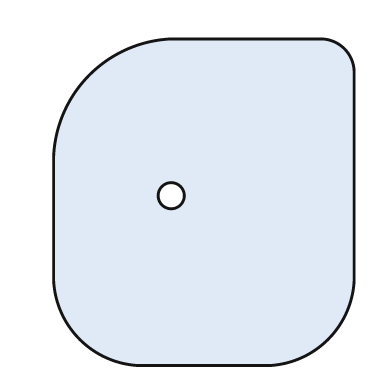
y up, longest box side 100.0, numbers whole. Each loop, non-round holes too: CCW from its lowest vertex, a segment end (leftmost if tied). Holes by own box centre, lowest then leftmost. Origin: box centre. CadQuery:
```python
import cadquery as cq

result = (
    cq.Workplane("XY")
    .moveTo(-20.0, -50.0)
    .lineTo(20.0, -50.0)
    .threePointArc((38.0, -42.0), (46.0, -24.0))
    .lineTo(46.0, 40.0)
    .threePointArc((43.0, 47.0), (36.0, 50.0))
    .lineTo(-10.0, 50.0)
    .threePointArc((-35.0, 39.0), (-46.0, 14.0))
    .lineTo(-46.0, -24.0)
    .threePointArc((-38.0, -42.0), (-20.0, -50.0))
    .close()
    .moveTo(-10.0, 2.0)
    .circle(4.0)
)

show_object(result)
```